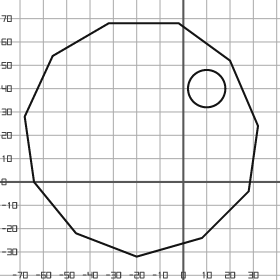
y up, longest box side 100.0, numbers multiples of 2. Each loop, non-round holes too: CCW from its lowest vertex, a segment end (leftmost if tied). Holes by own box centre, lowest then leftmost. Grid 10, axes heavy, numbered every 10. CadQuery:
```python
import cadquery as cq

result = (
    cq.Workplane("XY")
    .moveTo(-20.0, -32.0)
    .lineTo(8.0, -24.0)
    .lineTo(28.0, -4.0)
    .lineTo(32.0, 24.0)
    .lineTo(20.0, 52.0)
    .lineTo(-2.0, 68.0)
    .lineTo(-32.0, 68.0)
    .lineTo(-56.0, 54.0)
    .lineTo(-68.0, 28.0)
    .lineTo(-64.0, 0.0)
    .lineTo(-46.0, -22.0)
    .close()
    .moveTo(10.0, 40.0)
    .circle(8.0)
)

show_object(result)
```